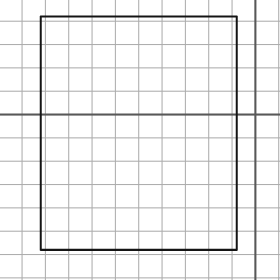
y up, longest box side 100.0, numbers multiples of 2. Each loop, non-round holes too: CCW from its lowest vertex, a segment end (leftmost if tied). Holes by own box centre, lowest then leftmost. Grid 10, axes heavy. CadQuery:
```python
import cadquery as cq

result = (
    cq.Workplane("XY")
    .moveTo(-92.0, -58.0)
    .lineTo(-8.0, -58.0)
    .lineTo(-8.0, 42.0)
    .lineTo(-92.0, 42.0)
    .close()
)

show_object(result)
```